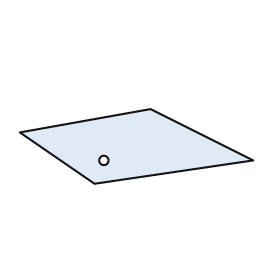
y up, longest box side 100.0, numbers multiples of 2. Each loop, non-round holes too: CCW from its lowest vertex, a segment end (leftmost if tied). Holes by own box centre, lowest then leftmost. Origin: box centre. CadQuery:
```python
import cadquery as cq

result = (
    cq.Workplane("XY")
    .moveTo(-18.0, -16.0)
    .lineTo(50.0, -6.0)
    .lineTo(6.0, 16.0)
    .lineTo(-50.0, 6.0)
    .close()
    .moveTo(-14.0, -6.0)
    .circle(2.0)
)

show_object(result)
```